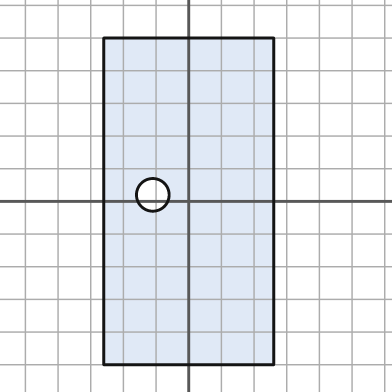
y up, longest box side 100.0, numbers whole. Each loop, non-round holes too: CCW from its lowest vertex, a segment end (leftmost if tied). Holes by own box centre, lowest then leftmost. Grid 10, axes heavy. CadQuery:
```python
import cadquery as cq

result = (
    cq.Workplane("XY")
    .moveTo(-26.0, -50.0)
    .lineTo(26.0, -50.0)
    .lineTo(26.0, 50.0)
    .lineTo(-26.0, 50.0)
    .close()
    .moveTo(-11.0, 2.0)
    .circle(5.0)
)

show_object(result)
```